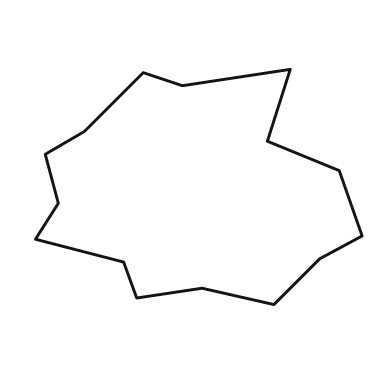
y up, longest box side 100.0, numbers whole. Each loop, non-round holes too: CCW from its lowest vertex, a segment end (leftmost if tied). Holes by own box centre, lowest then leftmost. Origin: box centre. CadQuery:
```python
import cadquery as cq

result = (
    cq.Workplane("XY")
    .moveTo(23.0, -36.0)
    .lineTo(37.0, -22.0)
    .lineTo(50.0, -15.0)
    .lineTo(43.0, 5.0)
    .lineTo(21.0, 14.0)
    .lineTo(28.0, 36.0)
    .lineTo(-5.0, 31.0)
    .lineTo(-17.0, 35.0)
    .lineTo(-35.0, 17.0)
    .lineTo(-47.0, 10.0)
    .lineTo(-43.0, -5.0)
    .lineTo(-50.0, -16.0)
    .lineTo(-23.0, -23.0)
    .lineTo(-19.0, -34.0)
    .lineTo(1.0, -31.0)
    .close()
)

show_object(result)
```